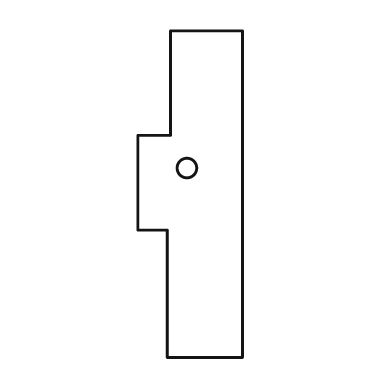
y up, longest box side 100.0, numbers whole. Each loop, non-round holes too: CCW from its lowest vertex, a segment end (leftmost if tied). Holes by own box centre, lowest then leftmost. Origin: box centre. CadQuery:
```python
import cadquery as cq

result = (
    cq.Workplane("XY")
    .moveTo(-7.0, -50.0)
    .lineTo(16.0, -50.0)
    .lineTo(16.0, 50.0)
    .lineTo(-6.0, 50.0)
    .lineTo(-6.0, 18.0)
    .lineTo(-16.0, 18.0)
    .lineTo(-16.0, -11.0)
    .lineTo(-7.0, -11.0)
    .close()
    .moveTo(-1.0, 8.0)
    .circle(3.0)
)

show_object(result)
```